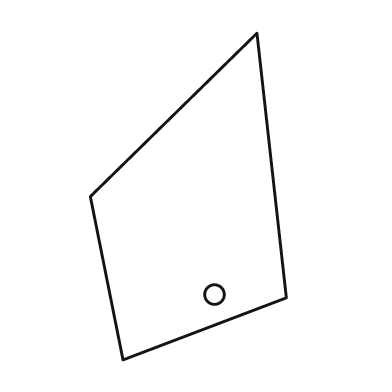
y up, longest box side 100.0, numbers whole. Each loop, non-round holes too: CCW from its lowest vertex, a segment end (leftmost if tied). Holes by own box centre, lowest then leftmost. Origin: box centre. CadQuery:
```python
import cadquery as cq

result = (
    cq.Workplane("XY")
    .moveTo(-20.0, -50.0)
    .lineTo(30.0, -31.0)
    .lineTo(21.0, 50.0)
    .lineTo(-30.0, 0.0)
    .close()
    .moveTo(8.0, -30.0)
    .circle(3.0)
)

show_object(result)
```